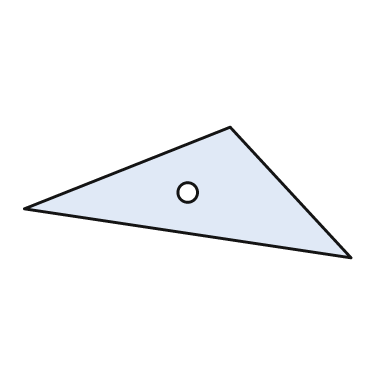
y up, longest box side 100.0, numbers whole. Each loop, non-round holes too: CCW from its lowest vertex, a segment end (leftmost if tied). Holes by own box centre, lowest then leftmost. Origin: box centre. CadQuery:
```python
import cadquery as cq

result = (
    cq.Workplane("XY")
    .moveTo(50.0, -20.0)
    .lineTo(13.0, 20.0)
    .lineTo(-50.0, -5.0)
    .close()
    .moveTo(0.0, 0.0)
    .circle(3.0)
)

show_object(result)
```